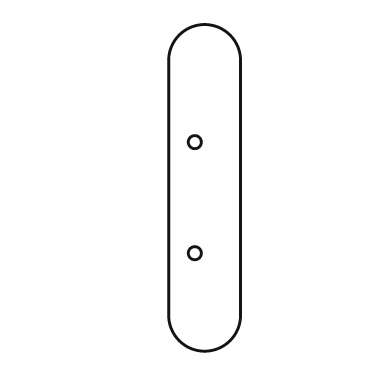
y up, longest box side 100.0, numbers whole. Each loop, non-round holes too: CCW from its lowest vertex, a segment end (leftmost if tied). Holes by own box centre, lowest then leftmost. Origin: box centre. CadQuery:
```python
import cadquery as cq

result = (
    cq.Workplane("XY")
    .moveTo(-11.0, -39.0)
    .threePointArc((0.0, -50.0), (11.0, -39.0))
    .lineTo(11.0, 39.0)
    .threePointArc((0.0, 50.0), (-11.0, 39.0))
    .close()
    .moveTo(-3.0, -20.0)
    .circle(2.0)
    .moveTo(-3.0, 14.0)
    .circle(2.0)
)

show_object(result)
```